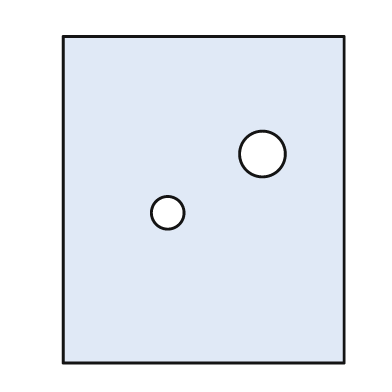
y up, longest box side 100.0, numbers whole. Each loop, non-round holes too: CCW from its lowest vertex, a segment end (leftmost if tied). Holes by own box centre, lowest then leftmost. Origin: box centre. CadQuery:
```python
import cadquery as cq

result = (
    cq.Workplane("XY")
    .moveTo(-43.0, -50.0)
    .lineTo(43.0, -50.0)
    .lineTo(43.0, 50.0)
    .lineTo(-43.0, 50.0)
    .close()
    .moveTo(-11.0, -4.0)
    .circle(5.0)
    .moveTo(18.0, 14.0)
    .circle(7.0)
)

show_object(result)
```